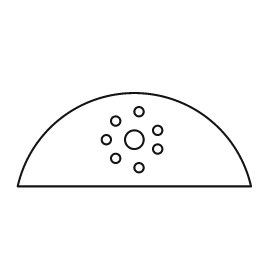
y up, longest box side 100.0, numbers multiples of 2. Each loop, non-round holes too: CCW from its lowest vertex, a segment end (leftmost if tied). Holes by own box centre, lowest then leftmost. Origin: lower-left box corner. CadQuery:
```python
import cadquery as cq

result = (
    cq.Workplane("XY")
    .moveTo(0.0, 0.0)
    .lineTo(100.0, 0.0)
    .threePointArc((50.0, 40.0), (0.0, 0.0))
    .close()
    .moveTo(52.0, 8.0)
    .circle(2.0)
    .moveTo(42.0, 12.0)
    .circle(2.0)
    .moveTo(60.0, 16.0)
    .circle(2.0)
    .moveTo(38.0, 20.0)
    .circle(2.0)
    .moveTo(50.0, 20.0)
    .circle(4.0)
    .moveTo(60.0, 24.0)
    .circle(2.0)
    .moveTo(42.0, 28.0)
    .circle(2.0)
    .moveTo(52.0, 32.0)
    .circle(2.0)
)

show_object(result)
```